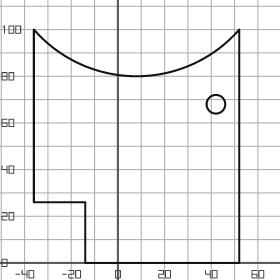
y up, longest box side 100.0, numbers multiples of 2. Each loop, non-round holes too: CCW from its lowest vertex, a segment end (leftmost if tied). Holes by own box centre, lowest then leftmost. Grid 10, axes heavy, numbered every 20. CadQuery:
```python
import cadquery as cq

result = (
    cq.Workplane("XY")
    .moveTo(-14.0, 0.0)
    .lineTo(52.0, 0.0)
    .lineTo(52.0, 100.0)
    .threePointArc((8.0, 80.0), (-36.0, 100.0))
    .lineTo(-36.0, 26.0)
    .lineTo(-14.0, 26.0)
    .close()
    .moveTo(42.0, 68.0)
    .circle(4.0)
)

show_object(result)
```